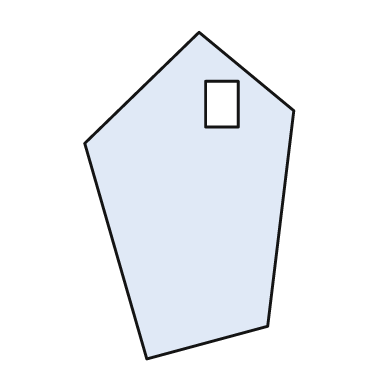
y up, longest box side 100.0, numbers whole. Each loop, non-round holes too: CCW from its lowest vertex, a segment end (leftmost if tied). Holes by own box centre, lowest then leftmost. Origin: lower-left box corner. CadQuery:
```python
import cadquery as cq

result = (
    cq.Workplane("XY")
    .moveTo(19.0, 0.0)
    .lineTo(56.0, 10.0)
    .lineTo(64.0, 76.0)
    .lineTo(35.0, 100.0)
    .lineTo(0.0, 66.0)
    .close()
    .moveTo(37.0, 71.0)
    .lineTo(47.0, 71.0)
    .lineTo(47.0, 85.0)
    .lineTo(37.0, 85.0)
    .close()
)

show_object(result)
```